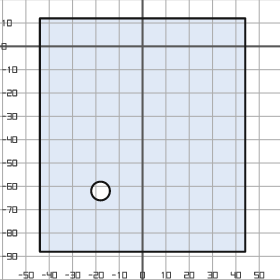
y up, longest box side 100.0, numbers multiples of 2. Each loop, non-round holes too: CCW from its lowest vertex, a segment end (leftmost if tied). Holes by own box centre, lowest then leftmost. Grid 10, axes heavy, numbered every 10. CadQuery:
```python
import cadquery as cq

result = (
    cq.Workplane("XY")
    .moveTo(-44.0, -88.0)
    .lineTo(44.0, -88.0)
    .lineTo(44.0, 12.0)
    .lineTo(-44.0, 12.0)
    .close()
    .moveTo(-18.0, -62.0)
    .circle(4.0)
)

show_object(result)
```